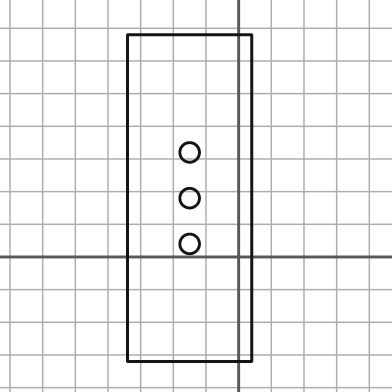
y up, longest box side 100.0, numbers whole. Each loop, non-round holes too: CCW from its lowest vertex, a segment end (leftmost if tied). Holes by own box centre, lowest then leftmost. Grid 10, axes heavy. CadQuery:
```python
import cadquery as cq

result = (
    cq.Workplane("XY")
    .moveTo(-34.0, -32.0)
    .lineTo(4.0, -32.0)
    .lineTo(4.0, 68.0)
    .lineTo(-34.0, 68.0)
    .close()
    .moveTo(-15.0, 4.0)
    .circle(3.0)
    .moveTo(-15.0, 18.0)
    .circle(3.0)
    .moveTo(-15.0, 32.0)
    .circle(3.0)
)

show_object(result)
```